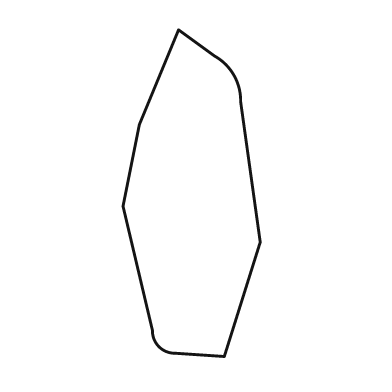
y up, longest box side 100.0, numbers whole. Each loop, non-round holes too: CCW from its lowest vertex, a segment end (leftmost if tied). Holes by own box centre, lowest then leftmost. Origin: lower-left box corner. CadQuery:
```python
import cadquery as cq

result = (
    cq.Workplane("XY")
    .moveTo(31.0, 0.0)
    .lineTo(42.0, 35.0)
    .lineTo(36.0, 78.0)
    .threePointArc((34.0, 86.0), (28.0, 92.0))
    .lineTo(17.0, 100.0)
    .lineTo(5.0, 71.0)
    .lineTo(0.0, 46.0)
    .lineTo(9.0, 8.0)
    .threePointArc((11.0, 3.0), (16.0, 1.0))
    .close()
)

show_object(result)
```